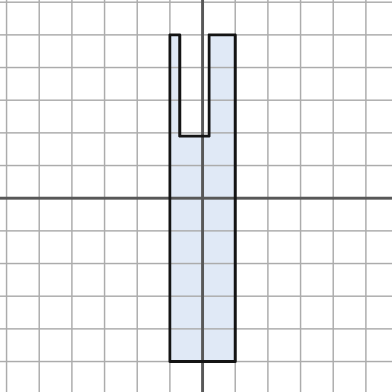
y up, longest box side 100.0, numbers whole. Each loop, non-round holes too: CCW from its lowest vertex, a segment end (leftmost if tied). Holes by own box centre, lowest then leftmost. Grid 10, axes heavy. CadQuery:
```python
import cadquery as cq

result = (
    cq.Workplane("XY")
    .moveTo(-10.0, -50.0)
    .lineTo(10.0, -50.0)
    .lineTo(10.0, 50.0)
    .lineTo(2.0, 50.0)
    .lineTo(2.0, 19.0)
    .lineTo(-7.0, 19.0)
    .lineTo(-7.0, 50.0)
    .lineTo(-10.0, 50.0)
    .close()
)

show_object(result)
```